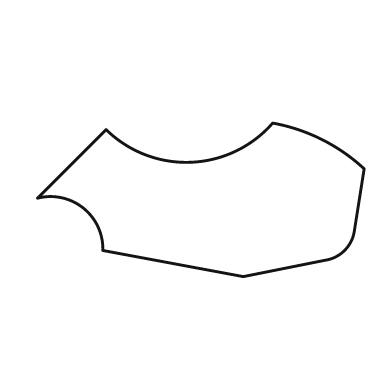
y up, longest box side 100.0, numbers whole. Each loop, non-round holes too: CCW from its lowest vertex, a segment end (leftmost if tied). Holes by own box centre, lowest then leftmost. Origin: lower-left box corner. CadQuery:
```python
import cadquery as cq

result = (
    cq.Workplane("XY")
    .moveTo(63.0, 0.0)
    .lineTo(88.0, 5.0)
    .threePointArc((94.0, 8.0), (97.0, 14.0))
    .lineTo(100.0, 33.0)
    .threePointArc((87.0, 42.0), (72.0, 47.0))
    .threePointArc((47.0, 35.0), (21.0, 45.0))
    .lineTo(0.0, 24.0)
    .threePointArc((14.0, 21.0), (20.0, 8.0))
    .close()
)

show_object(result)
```